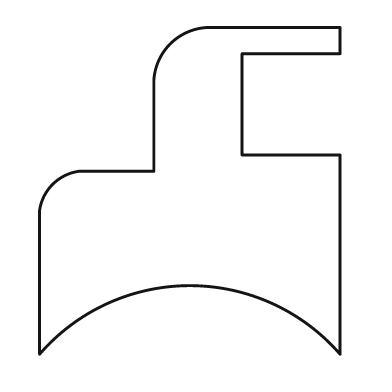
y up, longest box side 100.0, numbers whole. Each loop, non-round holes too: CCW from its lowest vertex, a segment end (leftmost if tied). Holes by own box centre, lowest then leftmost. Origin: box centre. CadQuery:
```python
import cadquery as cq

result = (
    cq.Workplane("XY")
    .moveTo(-46.0, -50.0)
    .threePointArc((0.0, -29.0), (46.0, -50.0))
    .lineTo(46.0, 11.0)
    .lineTo(16.0, 11.0)
    .lineTo(16.0, 42.0)
    .lineTo(46.0, 42.0)
    .lineTo(46.0, 50.0)
    .lineTo(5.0, 50.0)
    .threePointArc((-6.0, 45.0), (-11.0, 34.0))
    .lineTo(-11.0, 6.0)
    .lineTo(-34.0, 6.0)
    .threePointArc((-42.0, 2.0), (-46.0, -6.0))
    .close()
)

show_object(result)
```